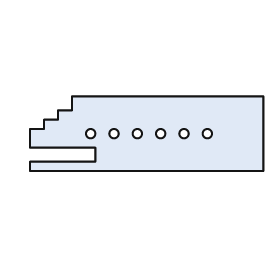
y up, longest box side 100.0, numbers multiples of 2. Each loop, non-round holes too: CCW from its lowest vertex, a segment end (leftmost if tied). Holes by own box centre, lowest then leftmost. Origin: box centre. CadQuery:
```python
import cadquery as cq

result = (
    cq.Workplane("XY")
    .moveTo(-50.0, -16.0)
    .lineTo(50.0, -16.0)
    .lineTo(50.0, 16.0)
    .lineTo(-32.0, 16.0)
    .lineTo(-32.0, 10.0)
    .lineTo(-38.0, 10.0)
    .lineTo(-38.0, 6.0)
    .lineTo(-44.0, 6.0)
    .lineTo(-44.0, 2.0)
    .lineTo(-50.0, 2.0)
    .lineTo(-50.0, -6.0)
    .lineTo(-22.0, -6.0)
    .lineTo(-22.0, -12.0)
    .lineTo(-50.0, -12.0)
    .close()
    .moveTo(-24.0, 0.0)
    .circle(2.0)
    .moveTo(-14.0, 0.0)
    .circle(2.0)
    .moveTo(-4.0, 0.0)
    .circle(2.0)
    .moveTo(6.0, 0.0)
    .circle(2.0)
    .moveTo(16.0, 0.0)
    .circle(2.0)
    .moveTo(26.0, 0.0)
    .circle(2.0)
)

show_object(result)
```